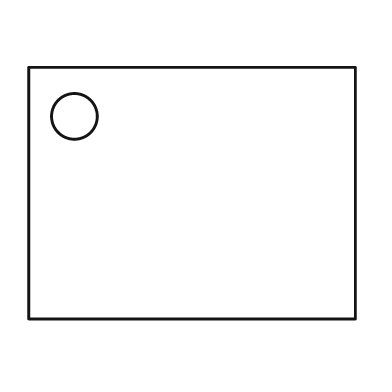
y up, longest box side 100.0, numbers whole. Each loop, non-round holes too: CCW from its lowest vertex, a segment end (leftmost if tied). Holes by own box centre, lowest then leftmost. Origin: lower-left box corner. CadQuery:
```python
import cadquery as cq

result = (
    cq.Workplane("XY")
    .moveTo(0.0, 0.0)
    .lineTo(100.0, 0.0)
    .lineTo(100.0, 77.0)
    .lineTo(0.0, 77.0)
    .close()
    .moveTo(14.0, 62.0)
    .circle(7.0)
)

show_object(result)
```